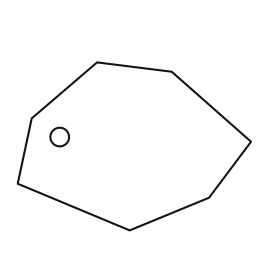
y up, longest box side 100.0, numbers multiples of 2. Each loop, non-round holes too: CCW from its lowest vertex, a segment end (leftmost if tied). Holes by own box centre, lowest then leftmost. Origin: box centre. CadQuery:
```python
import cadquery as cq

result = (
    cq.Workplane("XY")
    .moveTo(-2.0, -36.0)
    .lineTo(32.0, -22.0)
    .lineTo(50.0, 2.0)
    .lineTo(16.0, 32.0)
    .lineTo(-16.0, 36.0)
    .lineTo(-44.0, 12.0)
    .lineTo(-50.0, -16.0)
    .close()
    .moveTo(-32.0, 4.0)
    .circle(4.0)
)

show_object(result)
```